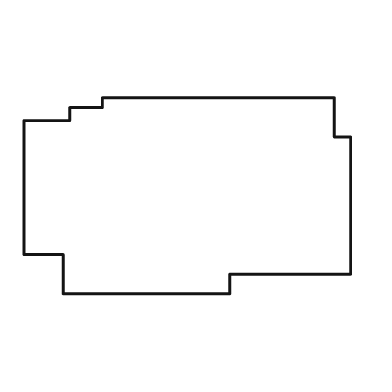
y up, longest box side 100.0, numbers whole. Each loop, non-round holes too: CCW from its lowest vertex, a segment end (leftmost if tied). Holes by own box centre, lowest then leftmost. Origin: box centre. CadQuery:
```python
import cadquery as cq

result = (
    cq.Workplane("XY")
    .moveTo(-38.0, -30.0)
    .lineTo(13.0, -30.0)
    .lineTo(13.0, -24.0)
    .lineTo(50.0, -24.0)
    .lineTo(50.0, 18.0)
    .lineTo(45.0, 18.0)
    .lineTo(45.0, 30.0)
    .lineTo(-26.0, 30.0)
    .lineTo(-26.0, 27.0)
    .lineTo(-36.0, 27.0)
    .lineTo(-36.0, 23.0)
    .lineTo(-50.0, 23.0)
    .lineTo(-50.0, -18.0)
    .lineTo(-38.0, -18.0)
    .close()
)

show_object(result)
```